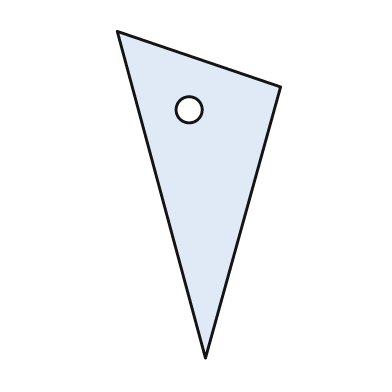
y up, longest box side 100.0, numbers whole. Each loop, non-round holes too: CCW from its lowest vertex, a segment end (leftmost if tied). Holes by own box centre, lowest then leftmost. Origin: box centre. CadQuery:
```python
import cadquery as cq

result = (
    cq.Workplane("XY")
    .moveTo(2.0, -50.0)
    .lineTo(25.0, 33.0)
    .lineTo(-25.0, 50.0)
    .close()
    .moveTo(-3.0, 26.0)
    .circle(4.0)
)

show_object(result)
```